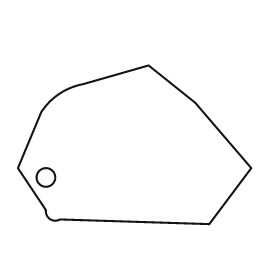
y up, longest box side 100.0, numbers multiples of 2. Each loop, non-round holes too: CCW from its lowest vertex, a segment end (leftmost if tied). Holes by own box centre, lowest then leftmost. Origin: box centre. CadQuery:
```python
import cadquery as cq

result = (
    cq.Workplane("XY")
    .moveTo(32.0, -34.0)
    .lineTo(50.0, -10.0)
    .lineTo(26.0, 18.0)
    .lineTo(6.0, 34.0)
    .lineTo(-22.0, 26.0)
    .threePointArc((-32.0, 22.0), (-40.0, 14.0))
    .lineTo(-50.0, -10.0)
    .lineTo(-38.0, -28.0)
    .threePointArc((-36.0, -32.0), (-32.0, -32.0))
    .close()
    .moveTo(-38.0, -14.0)
    .circle(4.0)
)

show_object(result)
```